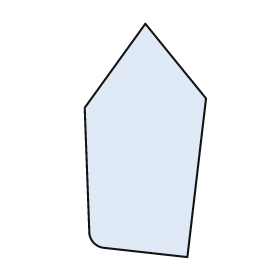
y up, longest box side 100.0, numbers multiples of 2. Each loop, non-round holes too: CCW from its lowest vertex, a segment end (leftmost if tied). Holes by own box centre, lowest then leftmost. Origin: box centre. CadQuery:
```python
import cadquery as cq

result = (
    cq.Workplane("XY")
    .moveTo(18.0, -50.0)
    .lineTo(26.0, 18.0)
    .lineTo(0.0, 50.0)
    .lineTo(-26.0, 14.0)
    .lineTo(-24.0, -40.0)
    .threePointArc((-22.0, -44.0), (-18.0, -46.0))
    .close()
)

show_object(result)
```